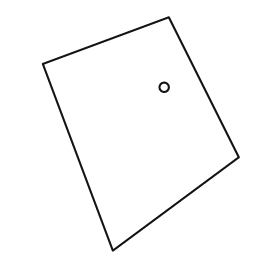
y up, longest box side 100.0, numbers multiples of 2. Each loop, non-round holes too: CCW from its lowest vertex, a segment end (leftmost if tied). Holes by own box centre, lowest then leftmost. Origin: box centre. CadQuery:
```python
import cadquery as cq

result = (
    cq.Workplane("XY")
    .moveTo(-12.0, -50.0)
    .lineTo(42.0, -10.0)
    .lineTo(12.0, 50.0)
    .lineTo(-42.0, 30.0)
    .close()
    .moveTo(10.0, 20.0)
    .circle(2.0)
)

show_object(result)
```